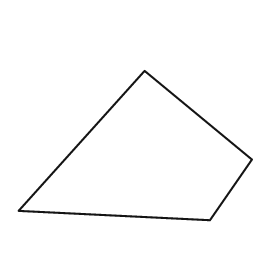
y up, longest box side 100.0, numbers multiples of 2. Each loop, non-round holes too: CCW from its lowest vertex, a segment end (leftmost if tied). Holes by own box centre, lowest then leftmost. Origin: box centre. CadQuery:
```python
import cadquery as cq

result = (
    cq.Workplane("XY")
    .moveTo(32.0, -32.0)
    .lineTo(50.0, -6.0)
    .lineTo(4.0, 32.0)
    .lineTo(-50.0, -28.0)
    .close()
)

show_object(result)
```